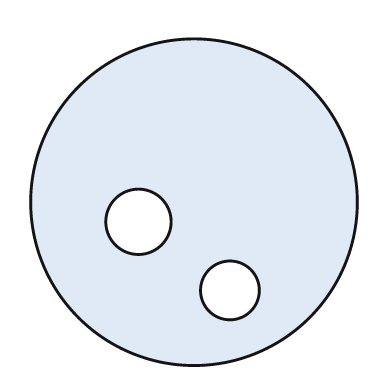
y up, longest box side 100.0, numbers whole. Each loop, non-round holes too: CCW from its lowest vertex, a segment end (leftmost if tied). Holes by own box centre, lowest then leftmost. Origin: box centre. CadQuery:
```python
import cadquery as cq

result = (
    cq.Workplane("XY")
    .moveTo(0.0, 0.0)
    .circle(50.0)
    .moveTo(11.0, -27.0)
    .circle(9.0)
    .moveTo(-17.0, -6.0)
    .circle(10.0)
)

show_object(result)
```